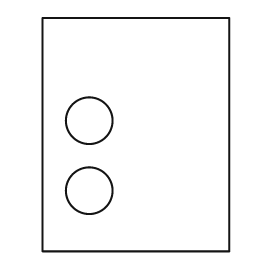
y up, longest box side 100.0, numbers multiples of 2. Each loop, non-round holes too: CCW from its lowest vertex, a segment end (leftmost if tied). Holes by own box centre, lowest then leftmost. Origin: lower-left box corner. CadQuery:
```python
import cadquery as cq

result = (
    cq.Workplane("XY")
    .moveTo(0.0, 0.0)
    .lineTo(80.0, 0.0)
    .lineTo(80.0, 100.0)
    .lineTo(0.0, 100.0)
    .close()
    .moveTo(20.0, 26.0)
    .circle(10.0)
    .moveTo(20.0, 56.0)
    .circle(10.0)
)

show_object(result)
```